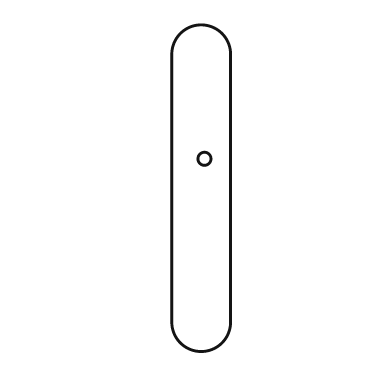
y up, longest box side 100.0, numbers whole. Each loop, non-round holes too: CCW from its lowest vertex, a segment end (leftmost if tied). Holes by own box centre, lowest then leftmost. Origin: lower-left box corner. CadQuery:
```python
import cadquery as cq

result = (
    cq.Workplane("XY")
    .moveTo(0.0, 9.0)
    .threePointArc((9.0, 0.0), (18.0, 9.0))
    .lineTo(18.0, 91.0)
    .threePointArc((9.0, 100.0), (0.0, 91.0))
    .close()
    .moveTo(10.0, 59.0)
    .circle(2.0)
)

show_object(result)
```